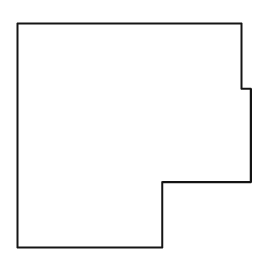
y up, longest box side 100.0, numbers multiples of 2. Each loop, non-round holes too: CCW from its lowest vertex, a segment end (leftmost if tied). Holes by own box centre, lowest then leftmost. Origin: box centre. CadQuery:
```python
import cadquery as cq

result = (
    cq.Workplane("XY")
    .moveTo(-50.0, -48.0)
    .lineTo(12.0, -48.0)
    .lineTo(12.0, -20.0)
    .lineTo(50.0, -20.0)
    .lineTo(50.0, 20.0)
    .lineTo(46.0, 20.0)
    .lineTo(46.0, 48.0)
    .lineTo(-50.0, 48.0)
    .close()
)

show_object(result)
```